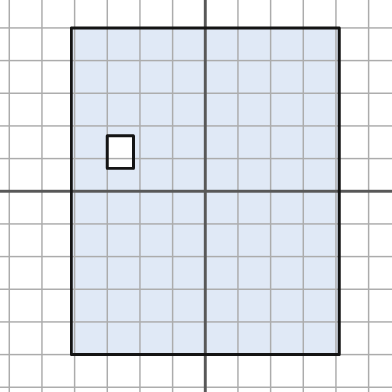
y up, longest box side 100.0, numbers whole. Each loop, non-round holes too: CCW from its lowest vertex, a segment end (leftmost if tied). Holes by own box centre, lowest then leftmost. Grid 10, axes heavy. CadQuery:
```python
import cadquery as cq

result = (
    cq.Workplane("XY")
    .moveTo(-41.0, -50.0)
    .lineTo(41.0, -50.0)
    .lineTo(41.0, 50.0)
    .lineTo(-41.0, 50.0)
    .close()
    .moveTo(-30.0, 7.0)
    .lineTo(-22.0, 7.0)
    .lineTo(-22.0, 17.0)
    .lineTo(-30.0, 17.0)
    .close()
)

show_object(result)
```